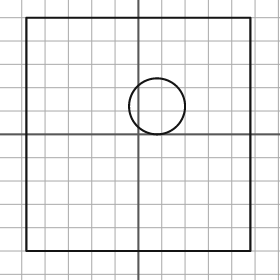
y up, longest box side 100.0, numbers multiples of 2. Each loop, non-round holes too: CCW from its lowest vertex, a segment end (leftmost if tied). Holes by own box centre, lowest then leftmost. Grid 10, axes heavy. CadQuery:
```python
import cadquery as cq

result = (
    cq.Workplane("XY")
    .moveTo(-48.0, -50.0)
    .lineTo(48.0, -50.0)
    .lineTo(48.0, 50.0)
    .lineTo(-48.0, 50.0)
    .close()
    .moveTo(8.0, 12.0)
    .circle(12.0)
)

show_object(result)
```